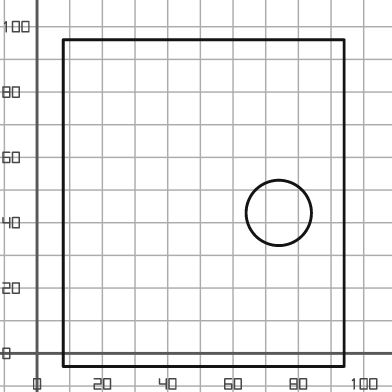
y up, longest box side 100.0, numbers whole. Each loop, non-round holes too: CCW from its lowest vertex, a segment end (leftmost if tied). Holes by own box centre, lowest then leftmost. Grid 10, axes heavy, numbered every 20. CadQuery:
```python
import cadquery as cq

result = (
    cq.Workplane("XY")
    .moveTo(8.0, -4.0)
    .lineTo(94.0, -4.0)
    .lineTo(94.0, 96.0)
    .lineTo(8.0, 96.0)
    .close()
    .moveTo(74.0, 43.0)
    .circle(10.0)
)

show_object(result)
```